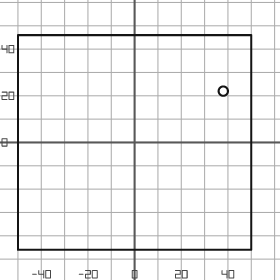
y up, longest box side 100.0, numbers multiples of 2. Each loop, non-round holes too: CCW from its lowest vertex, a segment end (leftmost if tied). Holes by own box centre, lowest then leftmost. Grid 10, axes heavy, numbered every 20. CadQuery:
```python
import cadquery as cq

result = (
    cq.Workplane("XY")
    .moveTo(-50.0, -46.0)
    .lineTo(50.0, -46.0)
    .lineTo(50.0, 46.0)
    .lineTo(-50.0, 46.0)
    .close()
    .moveTo(38.0, 22.0)
    .circle(2.0)
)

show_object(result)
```